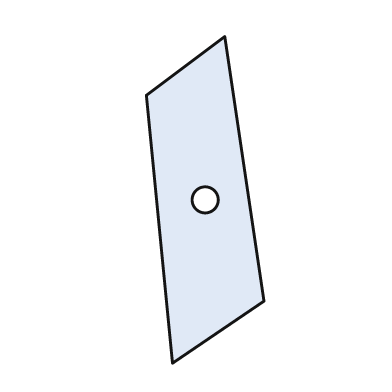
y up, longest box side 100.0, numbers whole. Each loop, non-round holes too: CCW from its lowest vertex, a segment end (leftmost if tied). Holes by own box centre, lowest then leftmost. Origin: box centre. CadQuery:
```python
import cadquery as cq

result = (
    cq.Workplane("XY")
    .moveTo(-10.0, -50.0)
    .lineTo(18.0, -31.0)
    .lineTo(6.0, 50.0)
    .lineTo(-18.0, 32.0)
    .close()
    .moveTo(0.0, 0.0)
    .circle(4.0)
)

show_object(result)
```